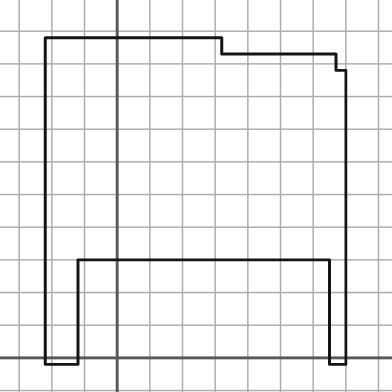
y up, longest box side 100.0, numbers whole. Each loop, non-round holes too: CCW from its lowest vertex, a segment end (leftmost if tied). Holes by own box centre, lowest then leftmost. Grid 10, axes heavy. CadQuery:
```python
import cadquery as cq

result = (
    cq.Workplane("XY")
    .moveTo(-22.0, -2.0)
    .lineTo(-12.0, -2.0)
    .lineTo(-12.0, 30.0)
    .lineTo(65.0, 30.0)
    .lineTo(65.0, -2.0)
    .lineTo(70.0, -2.0)
    .lineTo(70.0, 88.0)
    .lineTo(67.0, 88.0)
    .lineTo(67.0, 93.0)
    .lineTo(32.0, 93.0)
    .lineTo(32.0, 98.0)
    .lineTo(-22.0, 98.0)
    .close()
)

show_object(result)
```